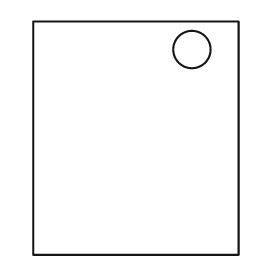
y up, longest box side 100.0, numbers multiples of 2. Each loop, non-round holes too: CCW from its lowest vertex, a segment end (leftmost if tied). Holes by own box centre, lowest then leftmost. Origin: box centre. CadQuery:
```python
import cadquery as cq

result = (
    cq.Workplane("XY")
    .moveTo(-44.0, -50.0)
    .lineTo(44.0, -50.0)
    .lineTo(44.0, 50.0)
    .lineTo(-44.0, 50.0)
    .close()
    .moveTo(24.0, 38.0)
    .circle(8.0)
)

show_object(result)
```